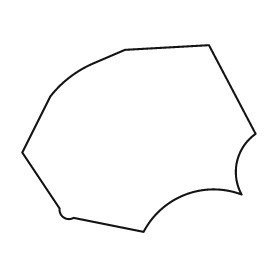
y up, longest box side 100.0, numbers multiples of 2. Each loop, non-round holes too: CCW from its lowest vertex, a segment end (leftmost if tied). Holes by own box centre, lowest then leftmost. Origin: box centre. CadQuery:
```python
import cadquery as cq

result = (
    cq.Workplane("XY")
    .moveTo(2.0, -40.0)
    .threePointArc((20.0, -24.0), (44.0, -24.0))
    .threePointArc((42.0, -10.0), (50.0, 2.0))
    .lineTo(30.0, 40.0)
    .lineTo(-6.0, 38.0)
    .lineTo(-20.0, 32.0)
    .threePointArc((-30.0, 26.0), (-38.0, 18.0))
    .lineTo(-50.0, -6.0)
    .lineTo(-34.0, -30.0)
    .threePointArc((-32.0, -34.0), (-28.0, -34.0))
    .close()
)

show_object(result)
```